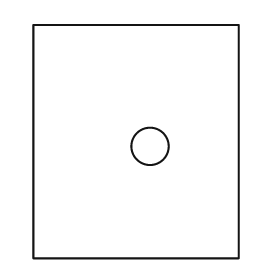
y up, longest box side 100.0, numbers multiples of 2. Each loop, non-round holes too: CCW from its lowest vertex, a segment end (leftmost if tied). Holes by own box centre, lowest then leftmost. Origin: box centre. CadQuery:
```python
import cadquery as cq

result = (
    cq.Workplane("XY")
    .moveTo(-44.0, -50.0)
    .lineTo(44.0, -50.0)
    .lineTo(44.0, 50.0)
    .lineTo(-44.0, 50.0)
    .close()
    .moveTo(6.0, -2.0)
    .circle(8.0)
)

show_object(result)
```